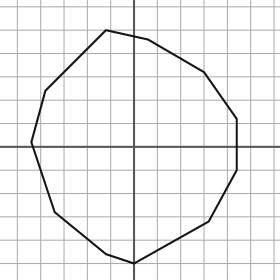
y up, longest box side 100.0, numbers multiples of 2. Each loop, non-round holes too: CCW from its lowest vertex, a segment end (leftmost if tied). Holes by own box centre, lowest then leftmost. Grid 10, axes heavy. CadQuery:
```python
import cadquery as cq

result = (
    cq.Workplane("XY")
    .moveTo(0.0, -50.0)
    .lineTo(32.0, -32.0)
    .lineTo(44.0, -10.0)
    .lineTo(44.0, 12.0)
    .lineTo(30.0, 32.0)
    .lineTo(6.0, 46.0)
    .lineTo(-12.0, 50.0)
    .lineTo(-38.0, 24.0)
    .lineTo(-44.0, 2.0)
    .lineTo(-34.0, -28.0)
    .lineTo(-12.0, -46.0)
    .close()
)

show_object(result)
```